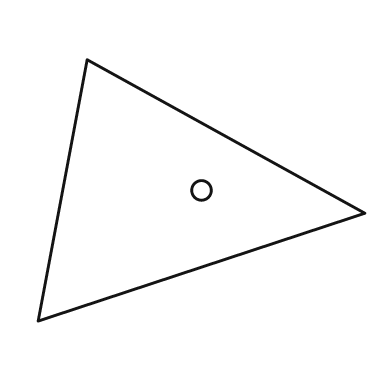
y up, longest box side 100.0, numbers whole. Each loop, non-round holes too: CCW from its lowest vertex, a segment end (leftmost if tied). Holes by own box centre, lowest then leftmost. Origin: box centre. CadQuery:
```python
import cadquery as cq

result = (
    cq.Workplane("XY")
    .moveTo(-50.0, -40.0)
    .lineTo(50.0, -7.0)
    .lineTo(-35.0, 40.0)
    .close()
    .moveTo(0.0, 0.0)
    .circle(3.0)
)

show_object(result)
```